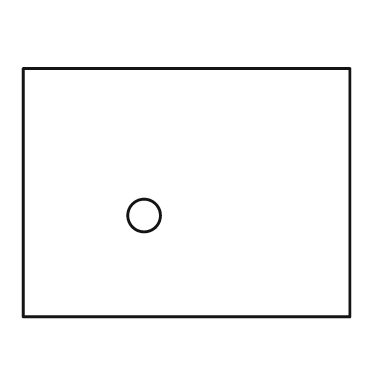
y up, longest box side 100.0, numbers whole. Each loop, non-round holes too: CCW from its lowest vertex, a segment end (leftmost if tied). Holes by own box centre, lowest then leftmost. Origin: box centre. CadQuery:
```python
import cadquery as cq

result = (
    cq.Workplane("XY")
    .moveTo(-50.0, -38.0)
    .lineTo(50.0, -38.0)
    .lineTo(50.0, 38.0)
    .lineTo(-50.0, 38.0)
    .close()
    .moveTo(-13.0, -7.0)
    .circle(5.0)
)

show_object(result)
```